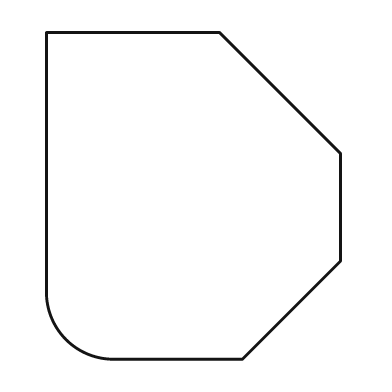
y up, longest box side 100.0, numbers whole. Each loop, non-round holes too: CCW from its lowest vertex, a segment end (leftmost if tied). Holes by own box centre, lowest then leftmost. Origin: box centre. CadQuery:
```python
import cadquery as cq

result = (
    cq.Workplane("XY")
    .moveTo(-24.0, -50.0)
    .lineTo(15.0, -50.0)
    .lineTo(45.0, -20.0)
    .lineTo(45.0, 13.0)
    .lineTo(8.0, 50.0)
    .lineTo(-45.0, 50.0)
    .lineTo(-45.0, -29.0)
    .threePointArc((-39.0, -44.0), (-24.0, -50.0))
    .close()
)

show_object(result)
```